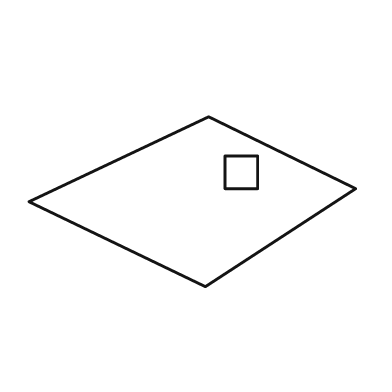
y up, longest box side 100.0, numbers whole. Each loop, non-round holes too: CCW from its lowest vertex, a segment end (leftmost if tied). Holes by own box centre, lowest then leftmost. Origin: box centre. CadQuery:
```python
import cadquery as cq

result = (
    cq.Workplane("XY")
    .moveTo(4.0, -26.0)
    .lineTo(50.0, 4.0)
    .lineTo(5.0, 26.0)
    .lineTo(-50.0, 0.0)
    .close()
    .moveTo(10.0, 4.0)
    .lineTo(20.0, 4.0)
    .lineTo(20.0, 14.0)
    .lineTo(10.0, 14.0)
    .close()
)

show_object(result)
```